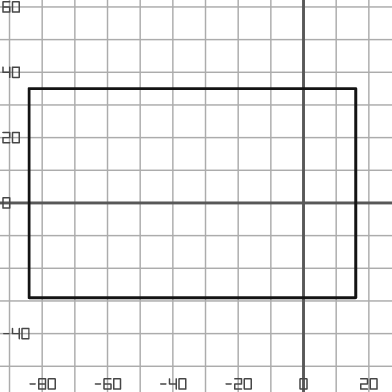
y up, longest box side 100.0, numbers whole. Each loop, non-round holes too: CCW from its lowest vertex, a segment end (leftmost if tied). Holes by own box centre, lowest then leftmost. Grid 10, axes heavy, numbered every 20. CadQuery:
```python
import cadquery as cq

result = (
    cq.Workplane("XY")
    .moveTo(-84.0, -29.0)
    .lineTo(16.0, -29.0)
    .lineTo(16.0, 35.0)
    .lineTo(-84.0, 35.0)
    .close()
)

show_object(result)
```